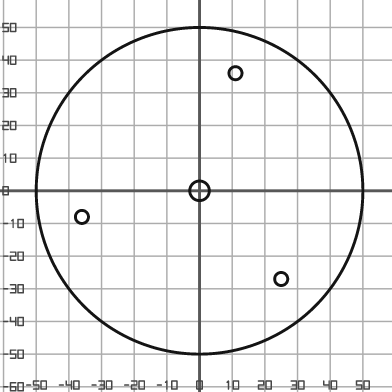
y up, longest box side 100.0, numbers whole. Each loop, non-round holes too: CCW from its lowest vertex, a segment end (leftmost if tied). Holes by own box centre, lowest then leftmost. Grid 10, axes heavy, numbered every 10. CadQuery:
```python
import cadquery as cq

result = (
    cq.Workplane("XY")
    .moveTo(0.0, 0.0)
    .circle(50.0)
    .moveTo(25.0, -27.0)
    .circle(2.0)
    .moveTo(-36.0, -8.0)
    .circle(2.0)
    .moveTo(0.0, 0.0)
    .circle(3.0)
    .moveTo(11.0, 36.0)
    .circle(2.0)
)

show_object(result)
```